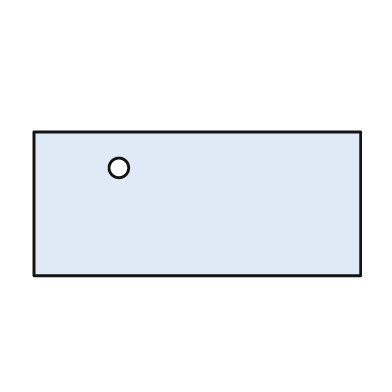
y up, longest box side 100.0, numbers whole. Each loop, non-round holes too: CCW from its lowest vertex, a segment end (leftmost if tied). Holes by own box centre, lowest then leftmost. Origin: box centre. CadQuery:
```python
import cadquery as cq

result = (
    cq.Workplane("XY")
    .moveTo(-50.0, -22.0)
    .lineTo(50.0, -22.0)
    .lineTo(50.0, 22.0)
    .lineTo(-50.0, 22.0)
    .close()
    .moveTo(-24.0, 11.0)
    .circle(3.0)
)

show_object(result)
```